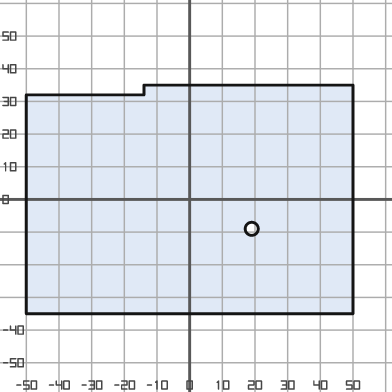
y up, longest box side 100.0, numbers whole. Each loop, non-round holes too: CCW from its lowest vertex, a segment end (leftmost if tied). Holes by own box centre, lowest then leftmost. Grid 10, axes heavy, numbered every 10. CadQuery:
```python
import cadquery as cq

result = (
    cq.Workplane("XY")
    .moveTo(-50.0, -35.0)
    .lineTo(50.0, -35.0)
    .lineTo(50.0, 35.0)
    .lineTo(-14.0, 35.0)
    .lineTo(-14.0, 32.0)
    .lineTo(-50.0, 32.0)
    .close()
    .moveTo(19.0, -9.0)
    .circle(2.0)
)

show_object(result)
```